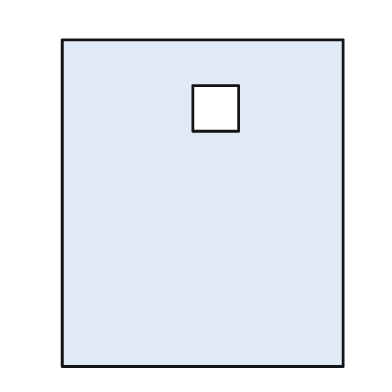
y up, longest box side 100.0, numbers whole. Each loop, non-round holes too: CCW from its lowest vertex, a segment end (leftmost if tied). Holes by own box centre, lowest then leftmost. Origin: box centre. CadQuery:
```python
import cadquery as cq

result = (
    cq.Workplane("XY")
    .moveTo(-43.0, -50.0)
    .lineTo(43.0, -50.0)
    .lineTo(43.0, 50.0)
    .lineTo(-43.0, 50.0)
    .close()
    .moveTo(-3.0, 22.0)
    .lineTo(11.0, 22.0)
    .lineTo(11.0, 36.0)
    .lineTo(-3.0, 36.0)
    .close()
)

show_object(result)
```